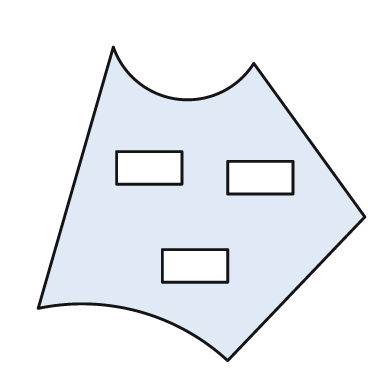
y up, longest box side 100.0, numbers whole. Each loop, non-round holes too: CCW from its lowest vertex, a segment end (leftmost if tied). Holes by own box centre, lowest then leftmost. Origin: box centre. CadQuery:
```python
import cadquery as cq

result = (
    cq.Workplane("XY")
    .moveTo(8.0, -48.0)
    .lineTo(50.0, -4.0)
    .lineTo(16.0, 43.0)
    .threePointArc((-7.0, 32.0), (-27.0, 48.0))
    .lineTo(-50.0, -32.0)
    .threePointArc((-19.0, -33.0), (8.0, -48.0))
    .close()
    .moveTo(-12.0, -24.0)
    .lineTo(8.0, -24.0)
    .lineTo(8.0, -14.0)
    .lineTo(-12.0, -14.0)
    .close()
    .moveTo(8.0, 3.0)
    .lineTo(28.0, 3.0)
    .lineTo(28.0, 13.0)
    .lineTo(8.0, 13.0)
    .close()
    .moveTo(-26.0, 6.0)
    .lineTo(-6.0, 6.0)
    .lineTo(-6.0, 16.0)
    .lineTo(-26.0, 16.0)
    .close()
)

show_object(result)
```